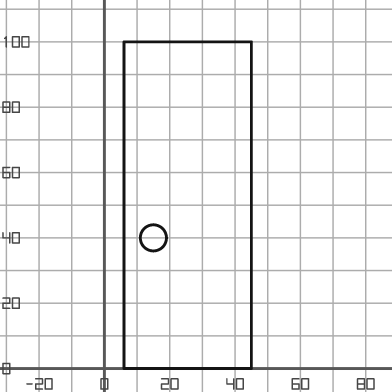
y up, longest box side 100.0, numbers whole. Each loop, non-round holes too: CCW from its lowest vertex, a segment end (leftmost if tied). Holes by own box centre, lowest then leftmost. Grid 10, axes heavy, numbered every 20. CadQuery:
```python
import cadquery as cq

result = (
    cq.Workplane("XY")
    .moveTo(6.0, 0.0)
    .lineTo(45.0, 0.0)
    .lineTo(45.0, 100.0)
    .lineTo(6.0, 100.0)
    .close()
    .moveTo(15.0, 40.0)
    .circle(4.0)
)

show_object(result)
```